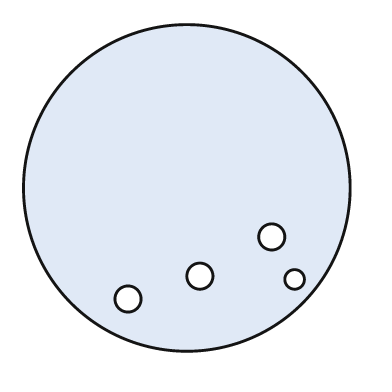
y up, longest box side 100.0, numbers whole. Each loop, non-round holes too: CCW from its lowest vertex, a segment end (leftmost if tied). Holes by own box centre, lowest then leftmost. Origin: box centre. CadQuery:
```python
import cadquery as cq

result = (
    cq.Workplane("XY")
    .moveTo(0.0, 0.0)
    .circle(50.0)
    .moveTo(-18.0, -34.0)
    .circle(4.0)
    .moveTo(33.0, -28.0)
    .circle(3.0)
    .moveTo(4.0, -27.0)
    .circle(4.0)
    .moveTo(26.0, -15.0)
    .circle(4.0)
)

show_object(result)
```